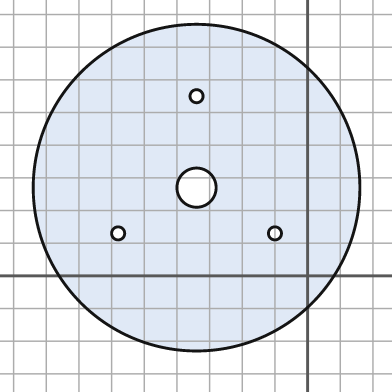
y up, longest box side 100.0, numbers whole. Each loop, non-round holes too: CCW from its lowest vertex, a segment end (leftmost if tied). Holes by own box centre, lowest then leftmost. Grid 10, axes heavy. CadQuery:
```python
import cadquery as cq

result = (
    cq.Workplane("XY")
    .moveTo(-34.0, 27.0)
    .circle(50.0)
    .moveTo(-58.0, 13.0)
    .circle(2.0)
    .moveTo(-10.0, 13.0)
    .circle(2.0)
    .moveTo(-34.0, 27.0)
    .circle(6.0)
    .moveTo(-34.0, 55.0)
    .circle(2.0)
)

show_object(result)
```